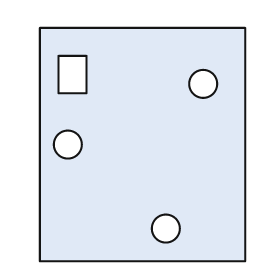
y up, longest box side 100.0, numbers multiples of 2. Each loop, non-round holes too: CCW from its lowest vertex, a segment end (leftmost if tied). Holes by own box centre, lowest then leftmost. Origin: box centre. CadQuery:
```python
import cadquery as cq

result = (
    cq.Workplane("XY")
    .moveTo(-44.0, -50.0)
    .lineTo(44.0, -50.0)
    .lineTo(44.0, 50.0)
    .lineTo(-44.0, 50.0)
    .close()
    .moveTo(10.0, -36.0)
    .circle(6.0)
    .moveTo(-32.0, 0.0)
    .circle(6.0)
    .moveTo(26.0, 26.0)
    .circle(6.0)
    .moveTo(-36.0, 22.0)
    .lineTo(-24.0, 22.0)
    .lineTo(-24.0, 38.0)
    .lineTo(-36.0, 38.0)
    .close()
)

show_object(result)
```